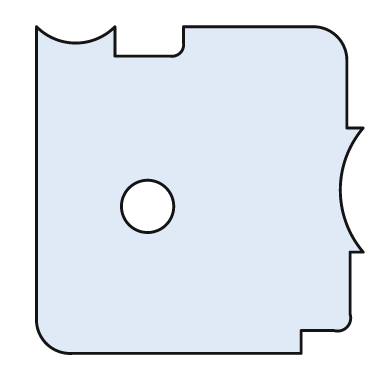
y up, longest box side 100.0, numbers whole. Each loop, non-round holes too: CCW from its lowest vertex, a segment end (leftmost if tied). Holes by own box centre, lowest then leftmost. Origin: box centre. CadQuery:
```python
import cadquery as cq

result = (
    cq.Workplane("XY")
    .moveTo(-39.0, -50.0)
    .lineTo(31.0, -50.0)
    .lineTo(31.0, -43.0)
    .lineTo(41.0, -43.0)
    .threePointArc((45.0, -42.0), (46.0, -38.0))
    .lineTo(46.0, -19.0)
    .lineTo(50.0, -19.0)
    .threePointArc((43.0, 0.0), (50.0, 19.0))
    .lineTo(45.0, 19.0)
    .lineTo(45.0, 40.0)
    .threePointArc((42.0, 47.0), (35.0, 50.0))
    .lineTo(-5.0, 50.0)
    .lineTo(-5.0, 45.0)
    .threePointArc((-6.0, 42.0), (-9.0, 41.0))
    .lineTo(-26.0, 41.0)
    .lineTo(-26.0, 50.0)
    .threePointArc((-38.0, 45.0), (-50.0, 50.0))
    .lineTo(-50.0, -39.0)
    .threePointArc((-47.0, -47.0), (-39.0, -50.0))
    .close()
    .moveTo(-16.0, -5.0)
    .circle(8.0)
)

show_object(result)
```